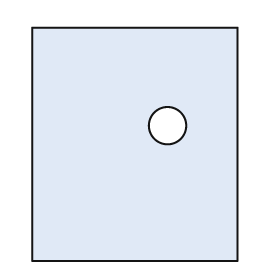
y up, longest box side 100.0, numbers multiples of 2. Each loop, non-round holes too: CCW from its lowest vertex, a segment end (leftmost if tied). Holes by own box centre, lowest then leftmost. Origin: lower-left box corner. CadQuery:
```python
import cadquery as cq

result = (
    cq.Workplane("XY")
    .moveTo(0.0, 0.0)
    .lineTo(88.0, 0.0)
    .lineTo(88.0, 100.0)
    .lineTo(0.0, 100.0)
    .close()
    .moveTo(58.0, 58.0)
    .circle(8.0)
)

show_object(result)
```